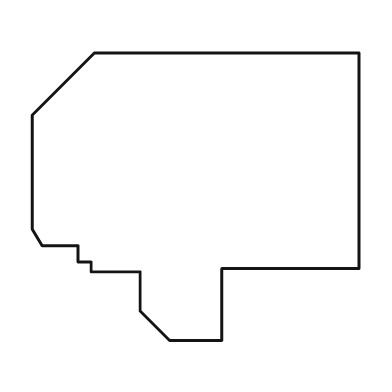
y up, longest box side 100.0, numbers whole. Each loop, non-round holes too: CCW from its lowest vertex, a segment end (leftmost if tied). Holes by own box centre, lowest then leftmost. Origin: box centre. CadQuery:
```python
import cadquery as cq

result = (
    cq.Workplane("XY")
    .moveTo(-8.0, -44.0)
    .lineTo(8.0, -44.0)
    .lineTo(8.0, -22.0)
    .lineTo(50.0, -22.0)
    .lineTo(50.0, 44.0)
    .lineTo(-31.0, 44.0)
    .lineTo(-50.0, 25.0)
    .lineTo(-50.0, -10.0)
    .lineTo(-47.0, -15.0)
    .lineTo(-36.0, -15.0)
    .lineTo(-36.0, -20.0)
    .lineTo(-32.0, -20.0)
    .lineTo(-32.0, -23.0)
    .lineTo(-17.0, -23.0)
    .lineTo(-17.0, -35.0)
    .close()
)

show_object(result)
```